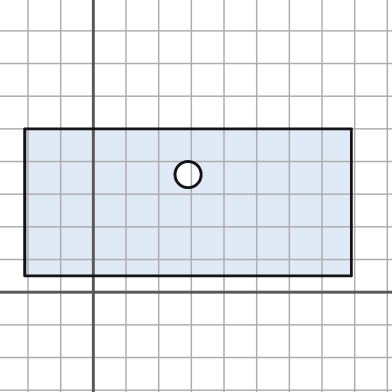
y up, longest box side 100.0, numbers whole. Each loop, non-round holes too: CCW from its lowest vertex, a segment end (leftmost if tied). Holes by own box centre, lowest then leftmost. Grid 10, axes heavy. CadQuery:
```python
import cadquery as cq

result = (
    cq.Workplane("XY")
    .moveTo(-21.0, 5.0)
    .lineTo(79.0, 5.0)
    .lineTo(79.0, 50.0)
    .lineTo(-21.0, 50.0)
    .close()
    .moveTo(29.0, 36.0)
    .circle(4.0)
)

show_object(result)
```